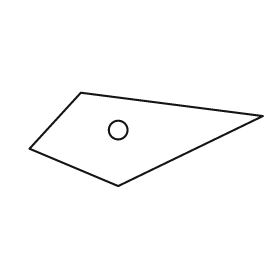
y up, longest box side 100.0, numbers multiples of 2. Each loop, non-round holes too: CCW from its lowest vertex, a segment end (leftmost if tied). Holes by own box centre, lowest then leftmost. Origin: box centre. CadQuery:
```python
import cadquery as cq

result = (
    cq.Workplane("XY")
    .moveTo(-12.0, -20.0)
    .lineTo(50.0, 10.0)
    .lineTo(-28.0, 20.0)
    .lineTo(-50.0, -4.0)
    .close()
    .moveTo(-12.0, 4.0)
    .circle(4.0)
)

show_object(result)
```